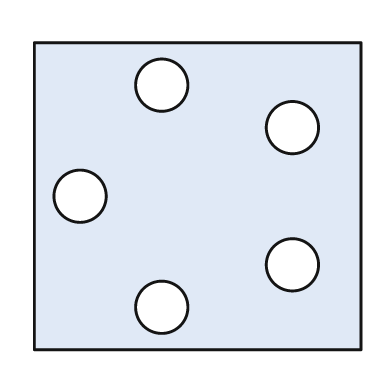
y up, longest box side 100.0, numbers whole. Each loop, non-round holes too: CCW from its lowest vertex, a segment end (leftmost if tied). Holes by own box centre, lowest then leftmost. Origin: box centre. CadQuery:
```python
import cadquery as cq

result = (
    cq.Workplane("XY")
    .moveTo(-50.0, -47.0)
    .lineTo(50.0, -47.0)
    .lineTo(50.0, 47.0)
    .lineTo(-50.0, 47.0)
    .close()
    .moveTo(-11.0, -34.0)
    .circle(8.0)
    .moveTo(29.0, -21.0)
    .circle(8.0)
    .moveTo(-36.0, 0.0)
    .circle(8.0)
    .moveTo(29.0, 21.0)
    .circle(8.0)
    .moveTo(-11.0, 34.0)
    .circle(8.0)
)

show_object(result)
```